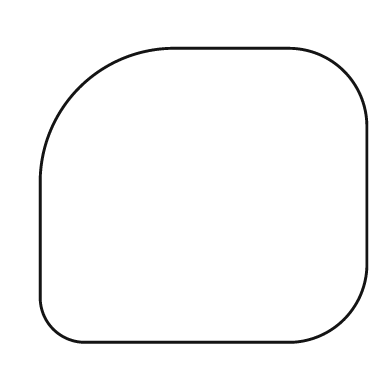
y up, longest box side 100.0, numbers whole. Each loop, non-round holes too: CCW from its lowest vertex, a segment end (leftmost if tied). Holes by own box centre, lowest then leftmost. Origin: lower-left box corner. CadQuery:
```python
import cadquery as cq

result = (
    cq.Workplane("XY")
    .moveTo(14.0, 0.0)
    .lineTo(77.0, 0.0)
    .threePointArc((93.0, 7.0), (100.0, 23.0))
    .lineTo(100.0, 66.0)
    .threePointArc((93.0, 83.0), (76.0, 90.0))
    .lineTo(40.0, 90.0)
    .threePointArc((12.0, 78.0), (0.0, 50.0))
    .lineTo(0.0, 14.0)
    .threePointArc((4.0, 4.0), (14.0, 0.0))
    .close()
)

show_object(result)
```